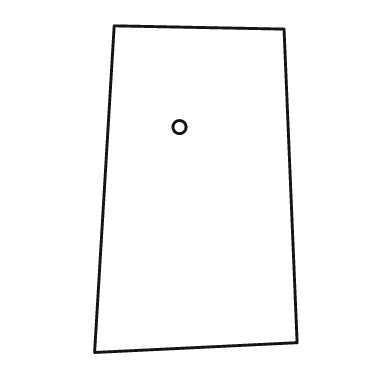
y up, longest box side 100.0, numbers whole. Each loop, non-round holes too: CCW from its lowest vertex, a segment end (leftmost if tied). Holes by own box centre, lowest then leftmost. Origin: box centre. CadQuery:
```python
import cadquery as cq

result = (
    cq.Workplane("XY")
    .moveTo(-31.0, -50.0)
    .lineTo(31.0, -47.0)
    .lineTo(27.0, 49.0)
    .lineTo(-25.0, 50.0)
    .close()
    .moveTo(-5.0, 19.0)
    .circle(2.0)
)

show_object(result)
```